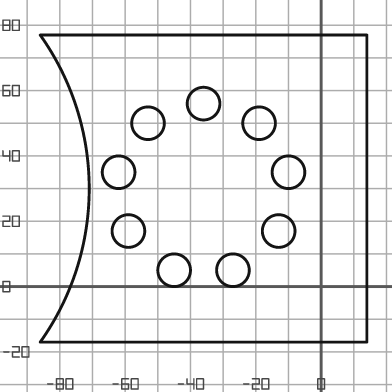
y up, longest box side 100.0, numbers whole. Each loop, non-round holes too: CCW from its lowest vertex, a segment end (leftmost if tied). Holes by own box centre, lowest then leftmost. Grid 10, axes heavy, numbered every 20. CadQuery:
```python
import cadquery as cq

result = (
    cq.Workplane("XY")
    .moveTo(-86.0, -17.0)
    .lineTo(14.0, -17.0)
    .lineTo(14.0, 77.0)
    .lineTo(-86.0, 77.0)
    .threePointArc((-71.0, 30.0), (-86.0, -17.0))
    .close()
    .moveTo(-45.0, 5.0)
    .circle(5.0)
    .moveTo(-27.0, 5.0)
    .circle(5.0)
    .moveTo(-59.0, 17.0)
    .circle(5.0)
    .moveTo(-13.0, 17.0)
    .circle(5.0)
    .moveTo(-62.0, 35.0)
    .circle(5.0)
    .moveTo(-10.0, 35.0)
    .circle(5.0)
    .moveTo(-53.0, 50.0)
    .circle(5.0)
    .moveTo(-19.0, 50.0)
    .circle(5.0)
    .moveTo(-36.0, 56.0)
    .circle(5.0)
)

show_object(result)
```